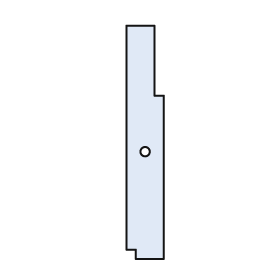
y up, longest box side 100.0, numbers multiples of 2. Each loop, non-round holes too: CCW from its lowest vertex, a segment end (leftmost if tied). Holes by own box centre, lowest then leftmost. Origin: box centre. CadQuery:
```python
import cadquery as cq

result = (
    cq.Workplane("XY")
    .moveTo(-4.0, -50.0)
    .lineTo(8.0, -50.0)
    .lineTo(8.0, 20.0)
    .lineTo(4.0, 20.0)
    .lineTo(4.0, 50.0)
    .lineTo(-8.0, 50.0)
    .lineTo(-8.0, -46.0)
    .lineTo(-4.0, -46.0)
    .close()
    .moveTo(0.0, -4.0)
    .circle(2.0)
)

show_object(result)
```